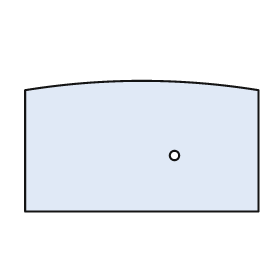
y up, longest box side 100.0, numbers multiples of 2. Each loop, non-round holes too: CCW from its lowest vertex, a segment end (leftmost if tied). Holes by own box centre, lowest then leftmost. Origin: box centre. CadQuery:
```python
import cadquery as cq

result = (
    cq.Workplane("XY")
    .moveTo(-50.0, -28.0)
    .lineTo(50.0, -28.0)
    .lineTo(50.0, 24.0)
    .threePointArc((0.0, 28.0), (-50.0, 24.0))
    .close()
    .moveTo(14.0, -4.0)
    .circle(2.0)
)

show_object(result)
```